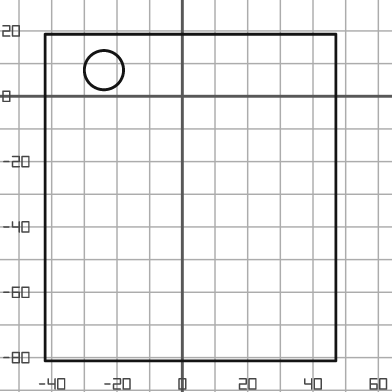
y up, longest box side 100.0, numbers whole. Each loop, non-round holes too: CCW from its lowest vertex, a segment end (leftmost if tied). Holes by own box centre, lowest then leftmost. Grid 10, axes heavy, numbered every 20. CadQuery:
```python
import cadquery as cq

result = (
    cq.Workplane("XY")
    .moveTo(-42.0, -81.0)
    .lineTo(47.0, -81.0)
    .lineTo(47.0, 19.0)
    .lineTo(-42.0, 19.0)
    .close()
    .moveTo(-24.0, 8.0)
    .circle(6.0)
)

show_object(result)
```